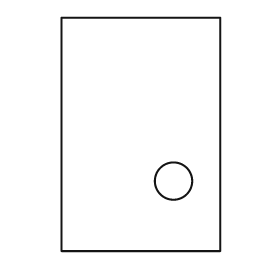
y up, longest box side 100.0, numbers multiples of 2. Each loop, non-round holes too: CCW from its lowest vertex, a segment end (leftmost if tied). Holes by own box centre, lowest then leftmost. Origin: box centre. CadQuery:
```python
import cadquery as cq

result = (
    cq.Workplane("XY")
    .moveTo(-34.0, -50.0)
    .lineTo(34.0, -50.0)
    .lineTo(34.0, 50.0)
    .lineTo(-34.0, 50.0)
    .close()
    .moveTo(14.0, -20.0)
    .circle(8.0)
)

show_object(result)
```